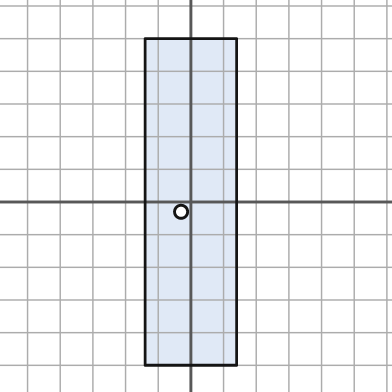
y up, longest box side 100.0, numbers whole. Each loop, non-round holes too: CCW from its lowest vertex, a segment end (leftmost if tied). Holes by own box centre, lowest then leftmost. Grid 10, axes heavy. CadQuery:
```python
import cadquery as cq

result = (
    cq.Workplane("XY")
    .moveTo(-14.0, -50.0)
    .lineTo(14.0, -50.0)
    .lineTo(14.0, 50.0)
    .lineTo(-14.0, 50.0)
    .close()
    .moveTo(-3.0, -3.0)
    .circle(2.0)
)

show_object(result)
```